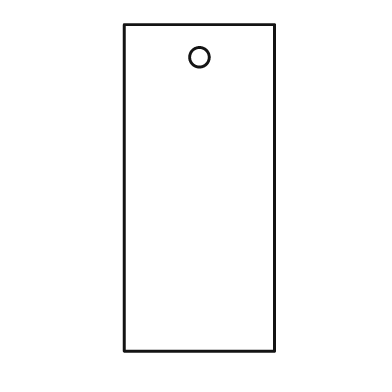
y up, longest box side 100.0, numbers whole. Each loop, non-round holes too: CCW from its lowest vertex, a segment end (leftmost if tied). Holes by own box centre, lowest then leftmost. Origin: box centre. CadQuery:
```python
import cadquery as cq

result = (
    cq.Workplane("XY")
    .moveTo(-23.0, -50.0)
    .lineTo(23.0, -50.0)
    .lineTo(23.0, 50.0)
    .lineTo(-23.0, 50.0)
    .close()
    .moveTo(0.0, 40.0)
    .circle(3.0)
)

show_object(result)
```